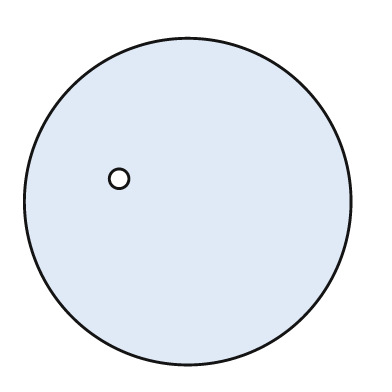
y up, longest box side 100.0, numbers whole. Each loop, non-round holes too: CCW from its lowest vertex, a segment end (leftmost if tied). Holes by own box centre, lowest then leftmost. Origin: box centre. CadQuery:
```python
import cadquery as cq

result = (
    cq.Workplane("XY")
    .moveTo(0.0, 0.0)
    .circle(50.0)
    .moveTo(-21.0, 7.0)
    .circle(3.0)
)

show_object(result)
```